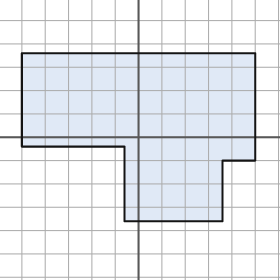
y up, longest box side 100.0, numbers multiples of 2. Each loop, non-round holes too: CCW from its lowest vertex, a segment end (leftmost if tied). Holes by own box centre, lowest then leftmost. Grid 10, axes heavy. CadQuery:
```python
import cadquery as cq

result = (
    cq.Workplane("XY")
    .moveTo(-6.0, -36.0)
    .lineTo(36.0, -36.0)
    .lineTo(36.0, -10.0)
    .lineTo(50.0, -10.0)
    .lineTo(50.0, 36.0)
    .lineTo(-50.0, 36.0)
    .lineTo(-50.0, -4.0)
    .lineTo(-6.0, -4.0)
    .close()
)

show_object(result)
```